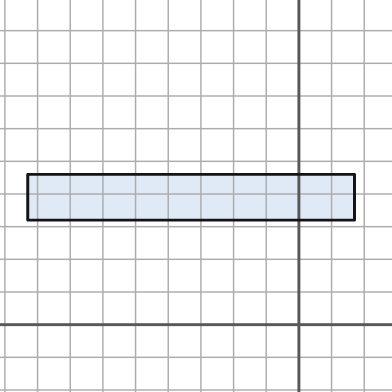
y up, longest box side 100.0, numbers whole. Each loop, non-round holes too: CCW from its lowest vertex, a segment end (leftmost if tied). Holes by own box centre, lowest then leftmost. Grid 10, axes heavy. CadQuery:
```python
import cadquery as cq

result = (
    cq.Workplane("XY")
    .moveTo(-83.0, 32.0)
    .lineTo(17.0, 32.0)
    .lineTo(17.0, 46.0)
    .lineTo(-83.0, 46.0)
    .close()
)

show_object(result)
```